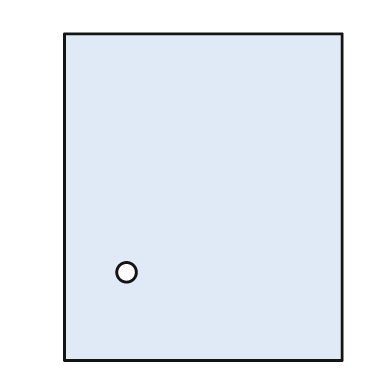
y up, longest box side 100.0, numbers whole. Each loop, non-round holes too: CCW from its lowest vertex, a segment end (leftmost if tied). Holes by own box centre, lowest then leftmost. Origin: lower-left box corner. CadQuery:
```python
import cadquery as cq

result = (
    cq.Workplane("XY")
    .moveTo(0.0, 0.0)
    .lineTo(85.0, 0.0)
    .lineTo(85.0, 100.0)
    .lineTo(0.0, 100.0)
    .close()
    .moveTo(19.0, 27.0)
    .circle(3.0)
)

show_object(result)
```